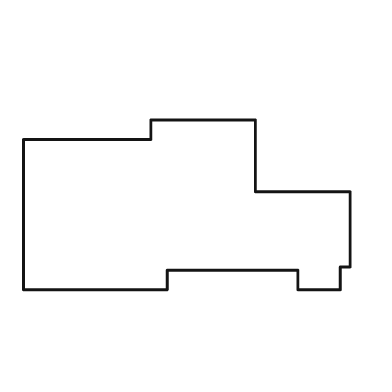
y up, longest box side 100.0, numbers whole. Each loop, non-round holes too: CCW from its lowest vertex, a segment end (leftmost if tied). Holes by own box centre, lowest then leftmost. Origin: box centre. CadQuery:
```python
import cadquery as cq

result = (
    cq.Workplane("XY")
    .moveTo(-50.0, -26.0)
    .lineTo(-6.0, -26.0)
    .lineTo(-6.0, -20.0)
    .lineTo(34.0, -20.0)
    .lineTo(34.0, -26.0)
    .lineTo(47.0, -26.0)
    .lineTo(47.0, -19.0)
    .lineTo(50.0, -19.0)
    .lineTo(50.0, 4.0)
    .lineTo(21.0, 4.0)
    .lineTo(21.0, 26.0)
    .lineTo(-11.0, 26.0)
    .lineTo(-11.0, 20.0)
    .lineTo(-50.0, 20.0)
    .close()
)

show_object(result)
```